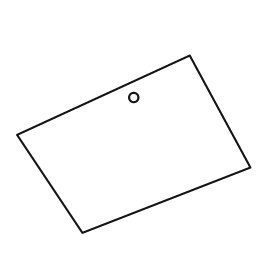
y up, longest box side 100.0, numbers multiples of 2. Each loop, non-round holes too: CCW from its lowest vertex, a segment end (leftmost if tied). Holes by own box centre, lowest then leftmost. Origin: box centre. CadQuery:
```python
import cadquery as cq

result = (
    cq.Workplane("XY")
    .moveTo(-22.0, -38.0)
    .lineTo(50.0, -10.0)
    .lineTo(24.0, 38.0)
    .lineTo(-50.0, 4.0)
    .close()
    .moveTo(0.0, 20.0)
    .circle(2.0)
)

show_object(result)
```